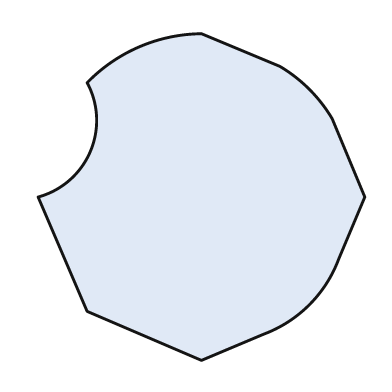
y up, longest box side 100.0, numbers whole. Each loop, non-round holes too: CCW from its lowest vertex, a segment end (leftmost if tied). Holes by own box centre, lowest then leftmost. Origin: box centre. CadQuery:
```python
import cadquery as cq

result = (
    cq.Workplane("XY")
    .moveTo(0.0, -50.0)
    .lineTo(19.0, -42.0)
    .threePointArc((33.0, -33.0), (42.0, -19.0))
    .lineTo(50.0, 0.0)
    .lineTo(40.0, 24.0)
    .threePointArc((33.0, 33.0), (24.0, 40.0))
    .lineTo(0.0, 50.0)
    .threePointArc((-19.0, 46.0), (-35.0, 35.0))
    .threePointArc((-34.0, 14.0), (-50.0, 0.0))
    .lineTo(-35.0, -35.0)
    .close()
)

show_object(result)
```